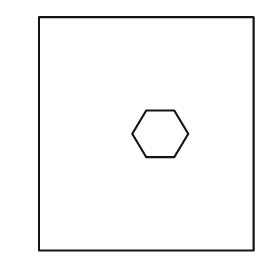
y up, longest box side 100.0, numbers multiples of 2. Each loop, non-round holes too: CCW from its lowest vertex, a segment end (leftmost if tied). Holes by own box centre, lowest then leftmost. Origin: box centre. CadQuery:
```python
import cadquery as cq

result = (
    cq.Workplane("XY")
    .moveTo(-46.0, -50.0)
    .lineTo(46.0, -50.0)
    .lineTo(46.0, 50.0)
    .lineTo(-46.0, 50.0)
    .close()
    .moveTo(0.0, -10.0)
    .lineTo(12.0, -10.0)
    .lineTo(18.0, 0.0)
    .lineTo(12.0, 10.0)
    .lineTo(0.0, 10.0)
    .lineTo(-6.0, 0.0)
    .close()
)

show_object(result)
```